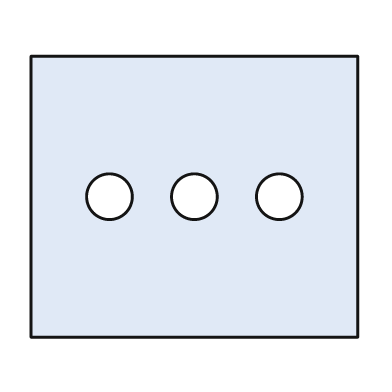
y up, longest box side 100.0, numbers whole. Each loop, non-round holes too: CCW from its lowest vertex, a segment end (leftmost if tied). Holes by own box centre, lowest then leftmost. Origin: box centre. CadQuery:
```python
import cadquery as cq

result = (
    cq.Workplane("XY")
    .moveTo(-50.0, -43.0)
    .lineTo(50.0, -43.0)
    .lineTo(50.0, 43.0)
    .lineTo(-50.0, 43.0)
    .close()
    .moveTo(-26.0, 0.0)
    .circle(7.0)
    .moveTo(0.0, 0.0)
    .circle(7.0)
    .moveTo(26.0, 0.0)
    .circle(7.0)
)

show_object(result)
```